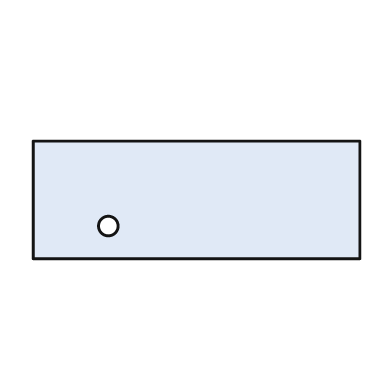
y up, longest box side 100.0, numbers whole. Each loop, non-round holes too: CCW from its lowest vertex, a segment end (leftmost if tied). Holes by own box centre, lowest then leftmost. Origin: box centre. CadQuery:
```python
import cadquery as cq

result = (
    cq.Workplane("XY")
    .moveTo(-50.0, -18.0)
    .lineTo(50.0, -18.0)
    .lineTo(50.0, 18.0)
    .lineTo(-50.0, 18.0)
    .close()
    .moveTo(-27.0, -8.0)
    .circle(3.0)
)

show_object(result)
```